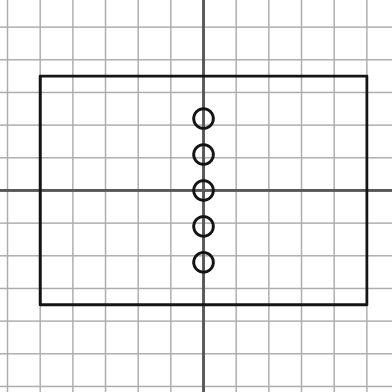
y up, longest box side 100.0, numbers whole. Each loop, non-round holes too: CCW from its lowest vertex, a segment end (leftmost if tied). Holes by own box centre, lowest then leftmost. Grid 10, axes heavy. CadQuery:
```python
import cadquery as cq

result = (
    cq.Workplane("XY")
    .moveTo(-50.0, -35.0)
    .lineTo(50.0, -35.0)
    .lineTo(50.0, 35.0)
    .lineTo(-50.0, 35.0)
    .close()
    .moveTo(0.0, -22.0)
    .circle(3.0)
    .moveTo(0.0, -11.0)
    .circle(3.0)
    .moveTo(0.0, 0.0)
    .circle(3.0)
    .moveTo(0.0, 11.0)
    .circle(3.0)
    .moveTo(0.0, 22.0)
    .circle(3.0)
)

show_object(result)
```